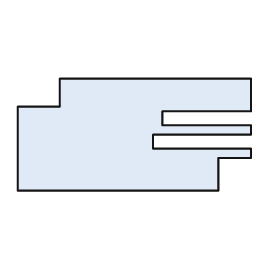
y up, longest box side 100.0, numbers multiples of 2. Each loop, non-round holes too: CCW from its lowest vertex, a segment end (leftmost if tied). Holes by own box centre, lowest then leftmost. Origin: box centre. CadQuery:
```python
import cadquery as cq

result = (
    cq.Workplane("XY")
    .moveTo(-50.0, -24.0)
    .lineTo(36.0, -24.0)
    .lineTo(36.0, -10.0)
    .lineTo(50.0, -10.0)
    .lineTo(50.0, -6.0)
    .lineTo(8.0, -6.0)
    .lineTo(8.0, 0.0)
    .lineTo(50.0, 0.0)
    .lineTo(50.0, 4.0)
    .lineTo(12.0, 4.0)
    .lineTo(12.0, 10.0)
    .lineTo(50.0, 10.0)
    .lineTo(50.0, 24.0)
    .lineTo(-32.0, 24.0)
    .lineTo(-32.0, 12.0)
    .lineTo(-50.0, 12.0)
    .close()
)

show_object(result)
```